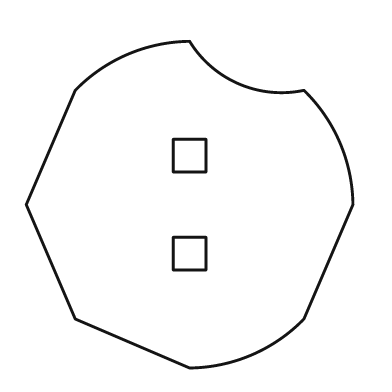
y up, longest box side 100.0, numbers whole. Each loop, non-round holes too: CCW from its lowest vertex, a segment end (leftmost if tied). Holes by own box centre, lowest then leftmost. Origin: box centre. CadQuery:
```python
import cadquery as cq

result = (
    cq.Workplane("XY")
    .moveTo(0.0, -50.0)
    .threePointArc((19.0, -46.0), (35.0, -35.0))
    .lineTo(50.0, 0.0)
    .threePointArc((46.0, 19.0), (35.0, 35.0))
    .threePointArc((15.0, 37.0), (0.0, 50.0))
    .threePointArc((-19.0, 46.0), (-35.0, 35.0))
    .lineTo(-50.0, 0.0)
    .lineTo(-35.0, -35.0)
    .close()
    .moveTo(-5.0, -20.0)
    .lineTo(5.0, -20.0)
    .lineTo(5.0, -10.0)
    .lineTo(-5.0, -10.0)
    .close()
    .moveTo(-5.0, 10.0)
    .lineTo(5.0, 10.0)
    .lineTo(5.0, 20.0)
    .lineTo(-5.0, 20.0)
    .close()
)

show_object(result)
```